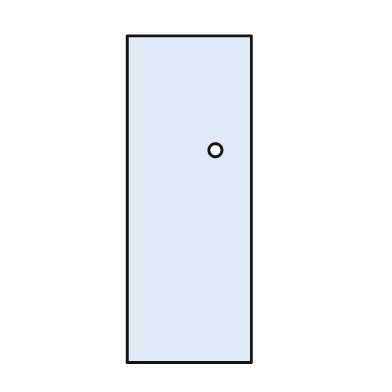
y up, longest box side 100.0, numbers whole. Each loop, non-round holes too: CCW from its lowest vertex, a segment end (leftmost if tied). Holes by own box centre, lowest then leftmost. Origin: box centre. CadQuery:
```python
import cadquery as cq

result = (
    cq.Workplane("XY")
    .moveTo(-19.0, -50.0)
    .lineTo(19.0, -50.0)
    .lineTo(19.0, 50.0)
    .lineTo(-19.0, 50.0)
    .close()
    .moveTo(8.0, 15.0)
    .circle(2.0)
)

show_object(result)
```